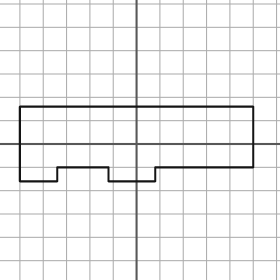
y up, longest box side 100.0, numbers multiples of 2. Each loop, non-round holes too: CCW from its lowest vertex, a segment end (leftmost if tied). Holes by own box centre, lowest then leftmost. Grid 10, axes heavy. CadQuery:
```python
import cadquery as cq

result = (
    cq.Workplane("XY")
    .moveTo(-50.0, -16.0)
    .lineTo(-34.0, -16.0)
    .lineTo(-34.0, -10.0)
    .lineTo(-12.0, -10.0)
    .lineTo(-12.0, -16.0)
    .lineTo(8.0, -16.0)
    .lineTo(8.0, -10.0)
    .lineTo(50.0, -10.0)
    .lineTo(50.0, 16.0)
    .lineTo(-50.0, 16.0)
    .close()
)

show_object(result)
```